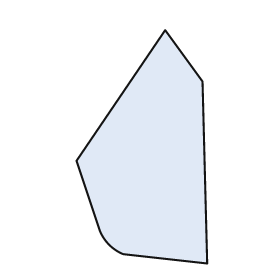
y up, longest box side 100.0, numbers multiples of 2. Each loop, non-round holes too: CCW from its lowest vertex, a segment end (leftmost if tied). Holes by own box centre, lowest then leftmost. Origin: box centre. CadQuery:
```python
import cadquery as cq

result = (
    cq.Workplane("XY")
    .moveTo(28.0, -50.0)
    .lineTo(26.0, 28.0)
    .lineTo(10.0, 50.0)
    .lineTo(-28.0, -6.0)
    .lineTo(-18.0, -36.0)
    .threePointArc((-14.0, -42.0), (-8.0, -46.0))
    .close()
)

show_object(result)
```